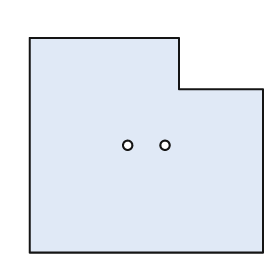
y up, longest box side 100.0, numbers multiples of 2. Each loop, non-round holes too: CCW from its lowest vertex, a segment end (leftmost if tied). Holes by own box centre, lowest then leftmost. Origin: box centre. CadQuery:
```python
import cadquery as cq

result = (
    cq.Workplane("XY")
    .moveTo(-50.0, -46.0)
    .lineTo(50.0, -46.0)
    .lineTo(50.0, 24.0)
    .lineTo(14.0, 24.0)
    .lineTo(14.0, 46.0)
    .lineTo(-50.0, 46.0)
    .close()
    .moveTo(-8.0, 0.0)
    .circle(2.0)
    .moveTo(8.0, 0.0)
    .circle(2.0)
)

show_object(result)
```